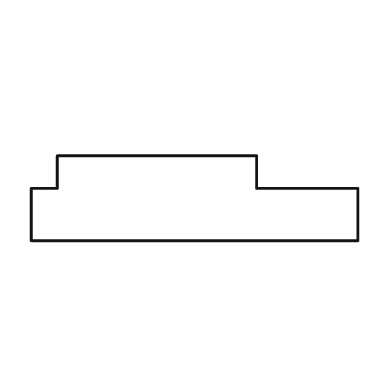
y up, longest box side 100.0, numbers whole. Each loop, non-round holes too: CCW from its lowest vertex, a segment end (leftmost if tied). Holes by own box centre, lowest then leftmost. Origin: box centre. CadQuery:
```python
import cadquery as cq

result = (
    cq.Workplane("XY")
    .moveTo(-50.0, -13.0)
    .lineTo(50.0, -13.0)
    .lineTo(50.0, 3.0)
    .lineTo(19.0, 3.0)
    .lineTo(19.0, 13.0)
    .lineTo(-42.0, 13.0)
    .lineTo(-42.0, 3.0)
    .lineTo(-50.0, 3.0)
    .close()
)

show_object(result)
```